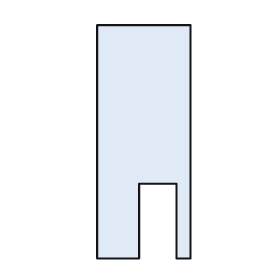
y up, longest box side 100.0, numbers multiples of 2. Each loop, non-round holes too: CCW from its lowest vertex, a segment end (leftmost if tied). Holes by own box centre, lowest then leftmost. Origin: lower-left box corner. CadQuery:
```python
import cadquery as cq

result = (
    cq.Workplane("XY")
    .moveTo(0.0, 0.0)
    .lineTo(18.0, 0.0)
    .lineTo(18.0, 32.0)
    .lineTo(34.0, 32.0)
    .lineTo(34.0, 0.0)
    .lineTo(40.0, 0.0)
    .lineTo(40.0, 100.0)
    .lineTo(0.0, 100.0)
    .close()
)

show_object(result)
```